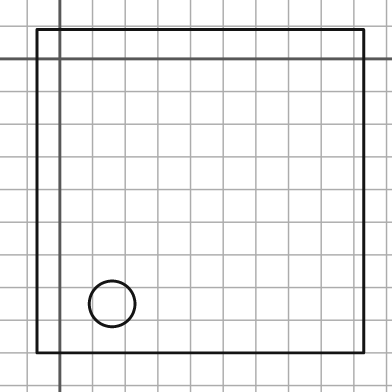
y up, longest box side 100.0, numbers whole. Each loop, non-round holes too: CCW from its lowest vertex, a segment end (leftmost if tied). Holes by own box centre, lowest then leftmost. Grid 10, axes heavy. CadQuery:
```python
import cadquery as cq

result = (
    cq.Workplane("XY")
    .moveTo(-7.0, -90.0)
    .lineTo(93.0, -90.0)
    .lineTo(93.0, 9.0)
    .lineTo(-7.0, 9.0)
    .close()
    .moveTo(16.0, -75.0)
    .circle(7.0)
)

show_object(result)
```